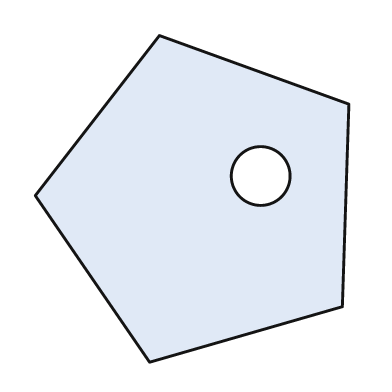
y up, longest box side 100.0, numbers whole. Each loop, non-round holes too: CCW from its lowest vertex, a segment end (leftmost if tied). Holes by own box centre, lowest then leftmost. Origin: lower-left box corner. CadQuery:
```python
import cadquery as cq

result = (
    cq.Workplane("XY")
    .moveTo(35.0, 0.0)
    .lineTo(94.0, 17.0)
    .lineTo(96.0, 79.0)
    .lineTo(38.0, 100.0)
    .lineTo(0.0, 51.0)
    .close()
    .moveTo(69.0, 57.0)
    .circle(9.0)
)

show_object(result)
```